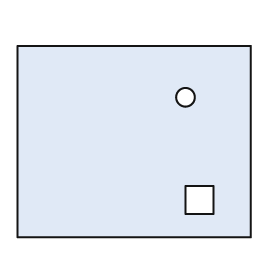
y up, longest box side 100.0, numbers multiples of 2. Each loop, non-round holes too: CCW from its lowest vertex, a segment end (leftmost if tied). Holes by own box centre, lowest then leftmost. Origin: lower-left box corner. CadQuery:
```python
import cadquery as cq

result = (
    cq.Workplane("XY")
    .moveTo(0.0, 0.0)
    .lineTo(100.0, 0.0)
    .lineTo(100.0, 82.0)
    .lineTo(0.0, 82.0)
    .close()
    .moveTo(72.0, 10.0)
    .lineTo(84.0, 10.0)
    .lineTo(84.0, 22.0)
    .lineTo(72.0, 22.0)
    .close()
    .moveTo(72.0, 60.0)
    .circle(4.0)
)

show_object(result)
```